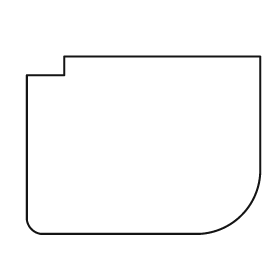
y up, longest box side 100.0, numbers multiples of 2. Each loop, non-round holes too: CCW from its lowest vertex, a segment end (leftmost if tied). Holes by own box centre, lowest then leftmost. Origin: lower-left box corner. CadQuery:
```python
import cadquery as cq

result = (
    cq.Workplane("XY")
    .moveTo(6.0, 0.0)
    .lineTo(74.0, 0.0)
    .threePointArc((92.0, 8.0), (100.0, 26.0))
    .lineTo(100.0, 76.0)
    .lineTo(16.0, 76.0)
    .lineTo(16.0, 68.0)
    .lineTo(0.0, 68.0)
    .lineTo(0.0, 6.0)
    .threePointArc((2.0, 2.0), (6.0, 0.0))
    .close()
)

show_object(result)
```